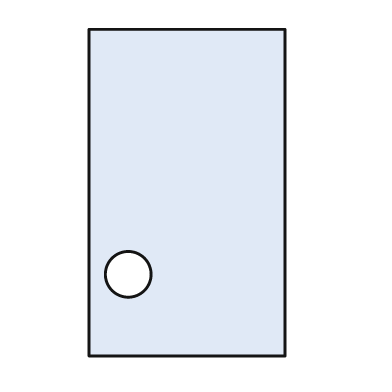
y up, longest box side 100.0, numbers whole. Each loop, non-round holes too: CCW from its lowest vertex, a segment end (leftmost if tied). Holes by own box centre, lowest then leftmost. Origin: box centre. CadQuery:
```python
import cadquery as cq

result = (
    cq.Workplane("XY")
    .moveTo(-30.0, -50.0)
    .lineTo(30.0, -50.0)
    .lineTo(30.0, 50.0)
    .lineTo(-30.0, 50.0)
    .close()
    .moveTo(-18.0, -25.0)
    .circle(7.0)
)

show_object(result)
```